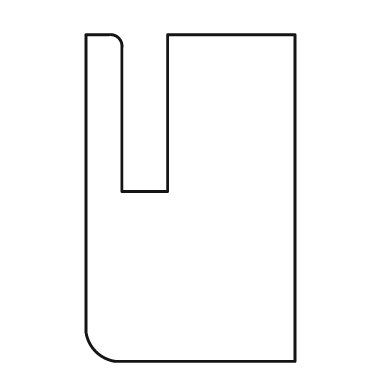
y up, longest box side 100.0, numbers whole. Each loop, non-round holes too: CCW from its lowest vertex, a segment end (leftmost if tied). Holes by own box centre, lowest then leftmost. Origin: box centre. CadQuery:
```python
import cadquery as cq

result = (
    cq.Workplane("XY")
    .moveTo(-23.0, -50.0)
    .lineTo(32.0, -50.0)
    .lineTo(32.0, 50.0)
    .lineTo(-7.0, 50.0)
    .lineTo(-7.0, 2.0)
    .lineTo(-21.0, 2.0)
    .lineTo(-21.0, 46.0)
    .threePointArc((-22.0, 49.0), (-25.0, 50.0))
    .lineTo(-32.0, 50.0)
    .lineTo(-32.0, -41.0)
    .threePointArc((-29.0, -47.0), (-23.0, -50.0))
    .close()
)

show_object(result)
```